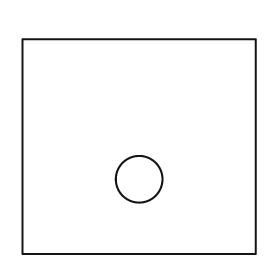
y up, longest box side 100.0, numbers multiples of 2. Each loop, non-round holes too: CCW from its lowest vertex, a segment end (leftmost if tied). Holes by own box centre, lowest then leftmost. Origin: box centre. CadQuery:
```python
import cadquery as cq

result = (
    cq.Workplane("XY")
    .moveTo(-50.0, -46.0)
    .lineTo(50.0, -46.0)
    .lineTo(50.0, 46.0)
    .lineTo(-50.0, 46.0)
    .close()
    .moveTo(0.0, -14.0)
    .circle(10.0)
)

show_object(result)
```